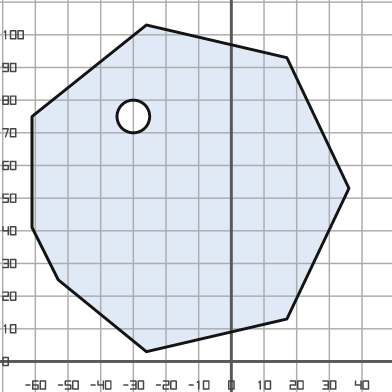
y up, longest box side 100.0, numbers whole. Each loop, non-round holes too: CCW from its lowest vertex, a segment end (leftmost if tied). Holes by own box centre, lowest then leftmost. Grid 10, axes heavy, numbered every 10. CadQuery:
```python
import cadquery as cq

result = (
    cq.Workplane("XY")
    .moveTo(-26.0, 3.0)
    .lineTo(17.0, 13.0)
    .lineTo(36.0, 53.0)
    .lineTo(17.0, 93.0)
    .lineTo(-26.0, 103.0)
    .lineTo(-61.0, 75.0)
    .lineTo(-61.0, 41.0)
    .lineTo(-53.0, 25.0)
    .close()
    .moveTo(-30.0, 75.0)
    .circle(5.0)
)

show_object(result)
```